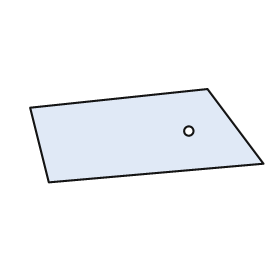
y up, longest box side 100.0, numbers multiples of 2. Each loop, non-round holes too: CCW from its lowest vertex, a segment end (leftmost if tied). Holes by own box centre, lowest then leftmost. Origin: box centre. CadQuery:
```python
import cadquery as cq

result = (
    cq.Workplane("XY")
    .moveTo(-42.0, -20.0)
    .lineTo(50.0, -12.0)
    .lineTo(26.0, 20.0)
    .lineTo(-50.0, 12.0)
    .close()
    .moveTo(18.0, 2.0)
    .circle(2.0)
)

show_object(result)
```